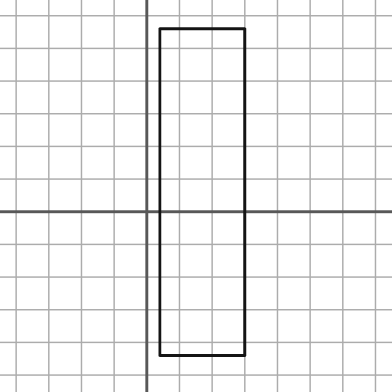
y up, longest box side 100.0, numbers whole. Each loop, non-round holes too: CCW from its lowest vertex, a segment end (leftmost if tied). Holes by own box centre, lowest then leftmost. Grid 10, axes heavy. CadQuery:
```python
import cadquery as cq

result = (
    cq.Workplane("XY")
    .moveTo(4.0, -44.0)
    .lineTo(30.0, -44.0)
    .lineTo(30.0, 56.0)
    .lineTo(4.0, 56.0)
    .close()
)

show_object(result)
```